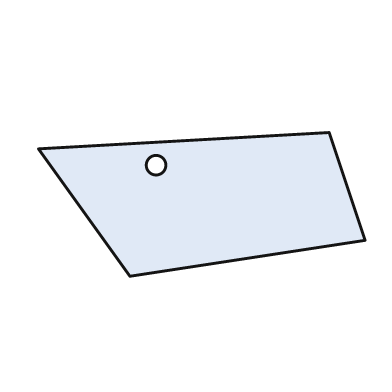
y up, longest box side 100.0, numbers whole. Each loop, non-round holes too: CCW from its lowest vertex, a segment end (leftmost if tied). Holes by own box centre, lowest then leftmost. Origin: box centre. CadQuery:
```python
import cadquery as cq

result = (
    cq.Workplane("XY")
    .moveTo(-22.0, -22.0)
    .lineTo(50.0, -11.0)
    .lineTo(39.0, 22.0)
    .lineTo(-50.0, 17.0)
    .close()
    .moveTo(-14.0, 12.0)
    .circle(3.0)
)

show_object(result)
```